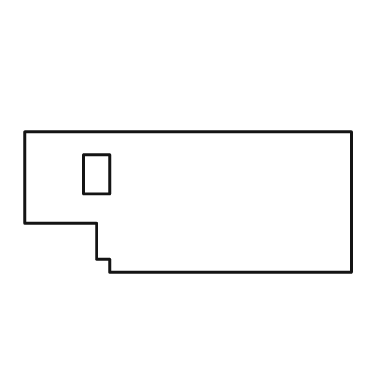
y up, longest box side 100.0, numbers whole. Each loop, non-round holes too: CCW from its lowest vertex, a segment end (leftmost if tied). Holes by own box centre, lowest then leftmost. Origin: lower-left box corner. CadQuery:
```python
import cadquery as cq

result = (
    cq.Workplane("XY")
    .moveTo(26.0, 0.0)
    .lineTo(100.0, 0.0)
    .lineTo(100.0, 43.0)
    .lineTo(0.0, 43.0)
    .lineTo(0.0, 15.0)
    .lineTo(22.0, 15.0)
    .lineTo(22.0, 4.0)
    .lineTo(26.0, 4.0)
    .close()
    .moveTo(18.0, 24.0)
    .lineTo(26.0, 24.0)
    .lineTo(26.0, 36.0)
    .lineTo(18.0, 36.0)
    .close()
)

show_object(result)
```